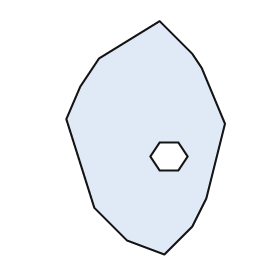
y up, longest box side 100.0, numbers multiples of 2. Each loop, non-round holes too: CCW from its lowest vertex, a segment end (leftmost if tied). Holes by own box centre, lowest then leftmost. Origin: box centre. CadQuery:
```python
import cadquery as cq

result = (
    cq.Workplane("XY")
    .moveTo(8.0, -50.0)
    .lineTo(20.0, -38.0)
    .lineTo(26.0, -26.0)
    .lineTo(34.0, 6.0)
    .lineTo(24.0, 30.0)
    .lineTo(20.0, 36.0)
    .lineTo(6.0, 50.0)
    .lineTo(-20.0, 34.0)
    .lineTo(-28.0, 22.0)
    .lineTo(-34.0, 8.0)
    .lineTo(-22.0, -30.0)
    .lineTo(-8.0, -44.0)
    .close()
    .moveTo(6.0, -14.0)
    .lineTo(14.0, -14.0)
    .lineTo(18.0, -8.0)
    .lineTo(14.0, -2.0)
    .lineTo(6.0, -2.0)
    .lineTo(2.0, -8.0)
    .close()
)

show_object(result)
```